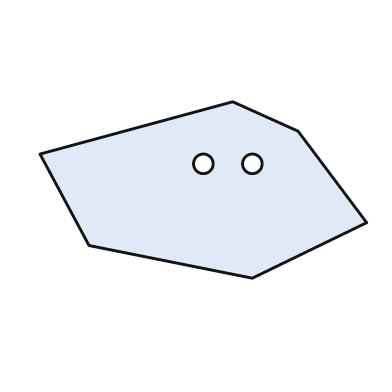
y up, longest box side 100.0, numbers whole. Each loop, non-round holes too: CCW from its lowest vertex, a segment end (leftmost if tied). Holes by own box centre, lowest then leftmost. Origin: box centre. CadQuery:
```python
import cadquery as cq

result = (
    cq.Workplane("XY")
    .moveTo(15.0, -27.0)
    .lineTo(50.0, -10.0)
    .lineTo(29.0, 18.0)
    .lineTo(9.0, 27.0)
    .lineTo(-50.0, 11.0)
    .lineTo(-35.0, -17.0)
    .close()
    .moveTo(0.0, 8.0)
    .circle(3.0)
    .moveTo(15.0, 8.0)
    .circle(3.0)
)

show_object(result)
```